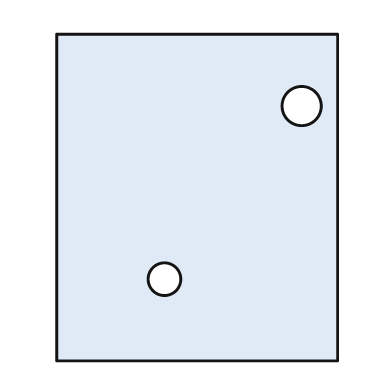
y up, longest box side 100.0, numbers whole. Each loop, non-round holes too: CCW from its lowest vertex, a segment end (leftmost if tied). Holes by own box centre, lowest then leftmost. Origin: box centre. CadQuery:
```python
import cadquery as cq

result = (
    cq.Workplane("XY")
    .moveTo(-43.0, -50.0)
    .lineTo(43.0, -50.0)
    .lineTo(43.0, 50.0)
    .lineTo(-43.0, 50.0)
    .close()
    .moveTo(-10.0, -25.0)
    .circle(5.0)
    .moveTo(32.0, 28.0)
    .circle(6.0)
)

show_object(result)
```